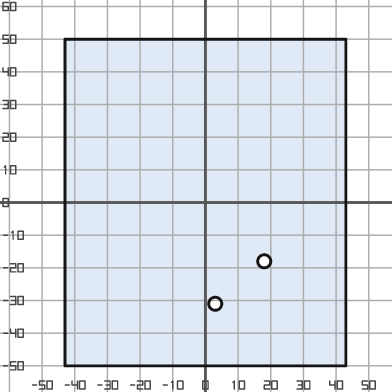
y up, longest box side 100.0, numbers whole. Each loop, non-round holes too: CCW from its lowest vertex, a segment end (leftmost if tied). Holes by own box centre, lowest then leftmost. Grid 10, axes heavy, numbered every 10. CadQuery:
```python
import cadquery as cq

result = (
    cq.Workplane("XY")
    .moveTo(-43.0, -50.0)
    .lineTo(43.0, -50.0)
    .lineTo(43.0, 50.0)
    .lineTo(-43.0, 50.0)
    .close()
    .moveTo(3.0, -31.0)
    .circle(2.0)
    .moveTo(18.0, -18.0)
    .circle(2.0)
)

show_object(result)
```